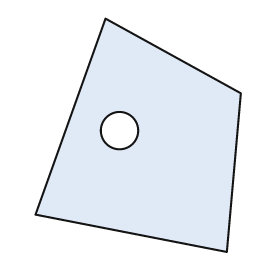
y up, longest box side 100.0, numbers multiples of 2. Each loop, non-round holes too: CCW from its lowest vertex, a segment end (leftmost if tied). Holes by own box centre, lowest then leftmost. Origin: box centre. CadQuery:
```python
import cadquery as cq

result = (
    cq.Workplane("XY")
    .moveTo(38.0, -50.0)
    .lineTo(44.0, 18.0)
    .lineTo(-14.0, 50.0)
    .lineTo(-44.0, -34.0)
    .close()
    .moveTo(-8.0, 2.0)
    .circle(8.0)
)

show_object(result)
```